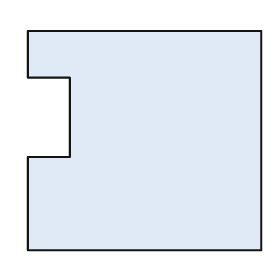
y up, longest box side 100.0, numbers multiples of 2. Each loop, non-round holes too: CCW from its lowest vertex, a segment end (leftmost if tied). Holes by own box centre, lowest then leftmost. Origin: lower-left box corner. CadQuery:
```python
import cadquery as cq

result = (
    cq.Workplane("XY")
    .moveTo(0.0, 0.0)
    .lineTo(100.0, 0.0)
    .lineTo(100.0, 94.0)
    .lineTo(0.0, 94.0)
    .lineTo(0.0, 74.0)
    .lineTo(18.0, 74.0)
    .lineTo(18.0, 40.0)
    .lineTo(0.0, 40.0)
    .close()
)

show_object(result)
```